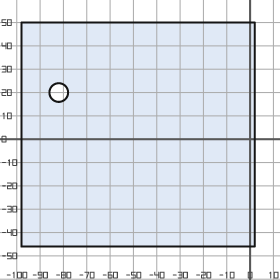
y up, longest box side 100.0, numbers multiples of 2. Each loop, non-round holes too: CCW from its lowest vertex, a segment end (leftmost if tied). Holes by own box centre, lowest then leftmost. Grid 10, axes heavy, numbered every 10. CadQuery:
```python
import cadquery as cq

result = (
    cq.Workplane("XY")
    .moveTo(-98.0, -46.0)
    .lineTo(2.0, -46.0)
    .lineTo(2.0, 50.0)
    .lineTo(-98.0, 50.0)
    .close()
    .moveTo(-82.0, 20.0)
    .circle(4.0)
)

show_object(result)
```